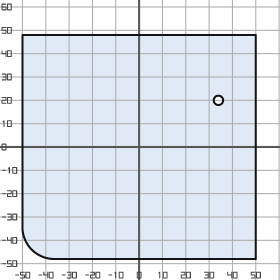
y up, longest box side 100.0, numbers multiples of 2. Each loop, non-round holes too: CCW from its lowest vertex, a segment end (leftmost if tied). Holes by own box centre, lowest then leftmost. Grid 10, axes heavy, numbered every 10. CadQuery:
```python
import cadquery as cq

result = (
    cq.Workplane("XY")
    .moveTo(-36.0, -48.0)
    .lineTo(50.0, -48.0)
    .lineTo(50.0, 48.0)
    .lineTo(-50.0, 48.0)
    .lineTo(-50.0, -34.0)
    .threePointArc((-46.0, -44.0), (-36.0, -48.0))
    .close()
    .moveTo(34.0, 20.0)
    .circle(2.0)
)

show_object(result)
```